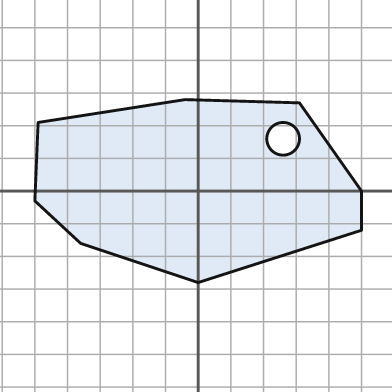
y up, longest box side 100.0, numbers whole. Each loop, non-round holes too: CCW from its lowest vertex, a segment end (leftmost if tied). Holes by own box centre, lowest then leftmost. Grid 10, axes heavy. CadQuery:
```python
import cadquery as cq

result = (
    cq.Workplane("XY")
    .moveTo(0.0, -28.0)
    .lineTo(50.0, -12.0)
    .lineTo(50.0, 0.0)
    .lineTo(31.0, 27.0)
    .lineTo(-4.0, 28.0)
    .lineTo(-49.0, 21.0)
    .lineTo(-50.0, -3.0)
    .lineTo(-36.0, -16.0)
    .close()
    .moveTo(26.0, 16.0)
    .circle(5.0)
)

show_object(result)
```